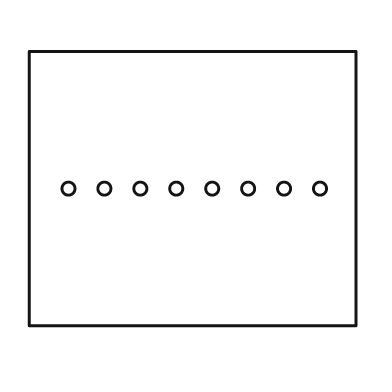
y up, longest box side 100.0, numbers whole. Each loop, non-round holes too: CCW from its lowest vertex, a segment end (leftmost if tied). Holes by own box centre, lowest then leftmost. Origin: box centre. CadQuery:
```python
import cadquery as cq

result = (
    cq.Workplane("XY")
    .moveTo(-50.0, -42.0)
    .lineTo(50.0, -42.0)
    .lineTo(50.0, 42.0)
    .lineTo(-50.0, 42.0)
    .close()
    .moveTo(-38.0, 0.0)
    .circle(2.0)
    .moveTo(-27.0, 0.0)
    .circle(2.0)
    .moveTo(-16.0, 0.0)
    .circle(2.0)
    .moveTo(-5.0, 0.0)
    .circle(2.0)
    .moveTo(6.0, 0.0)
    .circle(2.0)
    .moveTo(17.0, 0.0)
    .circle(2.0)
    .moveTo(28.0, 0.0)
    .circle(2.0)
    .moveTo(39.0, 0.0)
    .circle(2.0)
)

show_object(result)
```